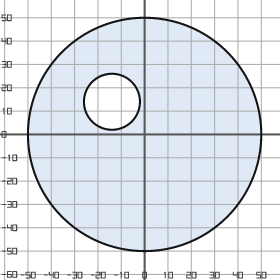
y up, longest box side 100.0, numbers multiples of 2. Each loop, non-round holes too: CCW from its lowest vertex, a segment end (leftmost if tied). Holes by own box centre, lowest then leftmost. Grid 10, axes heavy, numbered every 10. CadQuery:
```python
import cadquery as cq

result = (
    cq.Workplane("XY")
    .moveTo(0.0, 0.0)
    .circle(50.0)
    .moveTo(-14.0, 14.0)
    .circle(12.0)
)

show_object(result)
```